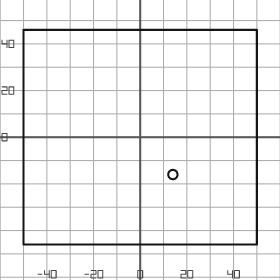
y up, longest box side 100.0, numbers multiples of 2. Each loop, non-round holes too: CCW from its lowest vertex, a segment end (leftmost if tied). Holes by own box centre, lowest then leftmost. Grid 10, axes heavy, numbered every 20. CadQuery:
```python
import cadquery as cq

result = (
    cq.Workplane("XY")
    .moveTo(-50.0, -46.0)
    .lineTo(50.0, -46.0)
    .lineTo(50.0, 46.0)
    .lineTo(-50.0, 46.0)
    .close()
    .moveTo(14.0, -16.0)
    .circle(2.0)
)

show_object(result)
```